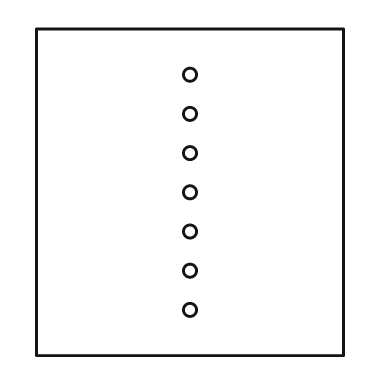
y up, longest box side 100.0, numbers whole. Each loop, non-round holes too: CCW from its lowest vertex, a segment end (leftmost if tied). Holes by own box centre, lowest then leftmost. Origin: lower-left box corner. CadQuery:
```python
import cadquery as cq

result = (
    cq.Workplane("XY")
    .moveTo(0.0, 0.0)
    .lineTo(94.0, 0.0)
    .lineTo(94.0, 100.0)
    .lineTo(0.0, 100.0)
    .close()
    .moveTo(47.0, 14.0)
    .circle(2.0)
    .moveTo(47.0, 26.0)
    .circle(2.0)
    .moveTo(47.0, 38.0)
    .circle(2.0)
    .moveTo(47.0, 50.0)
    .circle(2.0)
    .moveTo(47.0, 62.0)
    .circle(2.0)
    .moveTo(47.0, 74.0)
    .circle(2.0)
    .moveTo(47.0, 86.0)
    .circle(2.0)
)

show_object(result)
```